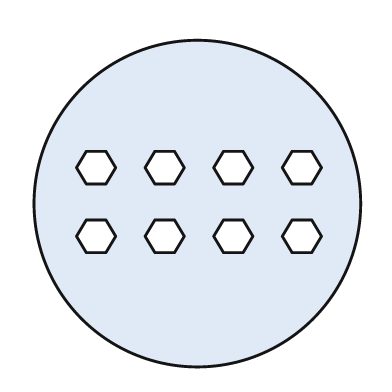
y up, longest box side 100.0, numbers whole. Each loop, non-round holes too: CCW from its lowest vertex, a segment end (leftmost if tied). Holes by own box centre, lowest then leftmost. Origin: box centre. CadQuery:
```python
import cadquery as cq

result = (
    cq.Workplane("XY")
    .moveTo(0.0, 0.0)
    .circle(50.0)
    .moveTo(-34.0, -15.0)
    .lineTo(-28.0, -15.0)
    .lineTo(-25.0, -10.0)
    .lineTo(-28.0, -5.0)
    .lineTo(-34.0, -5.0)
    .lineTo(-37.0, -10.0)
    .close()
    .moveTo(-13.0, -15.0)
    .lineTo(-7.0, -15.0)
    .lineTo(-4.0, -10.0)
    .lineTo(-7.0, -5.0)
    .lineTo(-13.0, -5.0)
    .lineTo(-16.0, -10.0)
    .close()
    .moveTo(8.0, -15.0)
    .lineTo(14.0, -15.0)
    .lineTo(17.0, -10.0)
    .lineTo(14.0, -5.0)
    .lineTo(8.0, -5.0)
    .lineTo(5.0, -10.0)
    .close()
    .moveTo(29.0, -15.0)
    .lineTo(35.0, -15.0)
    .lineTo(38.0, -10.0)
    .lineTo(35.0, -5.0)
    .lineTo(29.0, -5.0)
    .lineTo(26.0, -10.0)
    .close()
    .moveTo(-34.0, 6.0)
    .lineTo(-28.0, 6.0)
    .lineTo(-25.0, 11.0)
    .lineTo(-28.0, 16.0)
    .lineTo(-34.0, 16.0)
    .lineTo(-37.0, 11.0)
    .close()
    .moveTo(-13.0, 6.0)
    .lineTo(-7.0, 6.0)
    .lineTo(-4.0, 11.0)
    .lineTo(-7.0, 16.0)
    .lineTo(-13.0, 16.0)
    .lineTo(-16.0, 11.0)
    .close()
    .moveTo(8.0, 6.0)
    .lineTo(14.0, 6.0)
    .lineTo(17.0, 11.0)
    .lineTo(14.0, 16.0)
    .lineTo(8.0, 16.0)
    .lineTo(5.0, 11.0)
    .close()
    .moveTo(29.0, 6.0)
    .lineTo(35.0, 6.0)
    .lineTo(38.0, 11.0)
    .lineTo(35.0, 16.0)
    .lineTo(29.0, 16.0)
    .lineTo(26.0, 11.0)
    .close()
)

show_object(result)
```